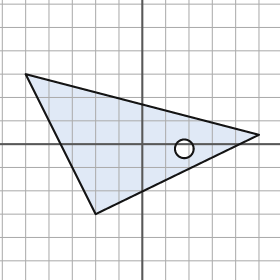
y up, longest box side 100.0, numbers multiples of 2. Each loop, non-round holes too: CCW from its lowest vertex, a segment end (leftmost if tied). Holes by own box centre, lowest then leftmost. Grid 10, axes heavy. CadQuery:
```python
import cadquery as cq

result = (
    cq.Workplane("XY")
    .moveTo(-20.0, -30.0)
    .lineTo(50.0, 4.0)
    .lineTo(-50.0, 30.0)
    .close()
    .moveTo(18.0, -2.0)
    .circle(4.0)
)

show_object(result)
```